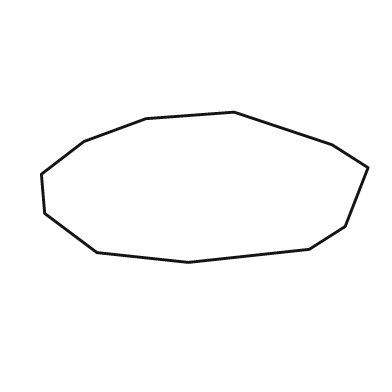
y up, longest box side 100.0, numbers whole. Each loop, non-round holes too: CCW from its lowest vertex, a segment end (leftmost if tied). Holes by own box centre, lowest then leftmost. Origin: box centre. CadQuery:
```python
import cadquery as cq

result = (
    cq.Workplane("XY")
    .moveTo(-5.0, -23.0)
    .lineTo(32.0, -19.0)
    .lineTo(43.0, -12.0)
    .lineTo(50.0, 6.0)
    .lineTo(39.0, 13.0)
    .lineTo(9.0, 23.0)
    .lineTo(-18.0, 21.0)
    .lineTo(-37.0, 14.0)
    .lineTo(-50.0, 4.0)
    .lineTo(-49.0, -8.0)
    .lineTo(-33.0, -20.0)
    .close()
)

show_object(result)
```